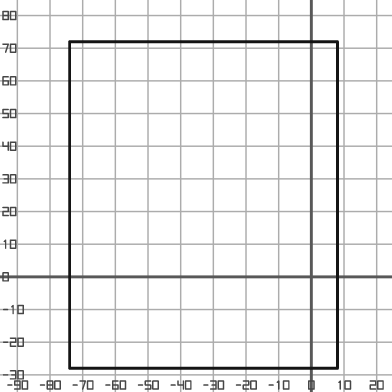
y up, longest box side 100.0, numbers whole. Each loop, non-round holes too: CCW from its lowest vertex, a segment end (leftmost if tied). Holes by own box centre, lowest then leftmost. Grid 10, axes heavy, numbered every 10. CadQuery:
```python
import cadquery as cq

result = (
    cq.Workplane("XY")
    .moveTo(-74.0, -28.0)
    .lineTo(8.0, -28.0)
    .lineTo(8.0, 72.0)
    .lineTo(-74.0, 72.0)
    .close()
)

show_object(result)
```